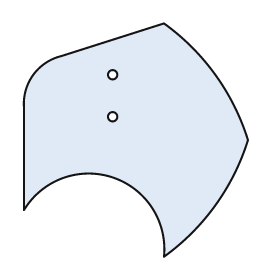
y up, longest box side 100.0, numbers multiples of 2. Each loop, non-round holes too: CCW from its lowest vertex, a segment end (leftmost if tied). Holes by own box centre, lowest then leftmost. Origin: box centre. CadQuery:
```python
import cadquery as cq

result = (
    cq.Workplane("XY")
    .moveTo(12.0, -50.0)
    .threePointArc((34.0, -28.0), (48.0, 0.0))
    .threePointArc((34.0, 28.0), (12.0, 50.0))
    .lineTo(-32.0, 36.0)
    .threePointArc((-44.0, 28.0), (-48.0, 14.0))
    .lineTo(-48.0, -30.0)
    .threePointArc((-10.0, -16.0), (12.0, -50.0))
    .close()
    .moveTo(-10.0, 10.0)
    .circle(2.0)
    .moveTo(-10.0, 28.0)
    .circle(2.0)
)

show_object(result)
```